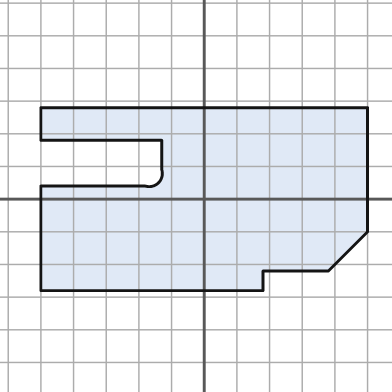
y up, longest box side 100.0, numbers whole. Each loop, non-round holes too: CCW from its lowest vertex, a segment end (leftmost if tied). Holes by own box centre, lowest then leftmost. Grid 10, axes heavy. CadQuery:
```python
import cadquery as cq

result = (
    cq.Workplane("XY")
    .moveTo(-50.0, -28.0)
    .lineTo(18.0, -28.0)
    .lineTo(18.0, -22.0)
    .lineTo(38.0, -22.0)
    .lineTo(50.0, -10.0)
    .lineTo(50.0, 28.0)
    .lineTo(-50.0, 28.0)
    .lineTo(-50.0, 18.0)
    .lineTo(-13.0, 18.0)
    .lineTo(-13.0, 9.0)
    .threePointArc((-14.0, 5.0), (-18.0, 4.0))
    .lineTo(-50.0, 4.0)
    .close()
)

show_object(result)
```